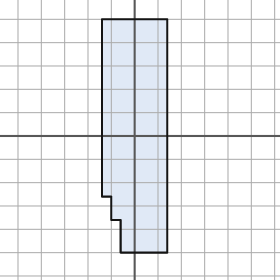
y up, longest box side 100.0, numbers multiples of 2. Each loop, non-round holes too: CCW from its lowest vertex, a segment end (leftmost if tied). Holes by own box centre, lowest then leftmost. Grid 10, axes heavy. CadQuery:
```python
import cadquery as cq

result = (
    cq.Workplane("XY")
    .moveTo(-6.0, -50.0)
    .lineTo(14.0, -50.0)
    .lineTo(14.0, 50.0)
    .lineTo(-14.0, 50.0)
    .lineTo(-14.0, -26.0)
    .lineTo(-10.0, -26.0)
    .lineTo(-10.0, -36.0)
    .lineTo(-6.0, -36.0)
    .close()
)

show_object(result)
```